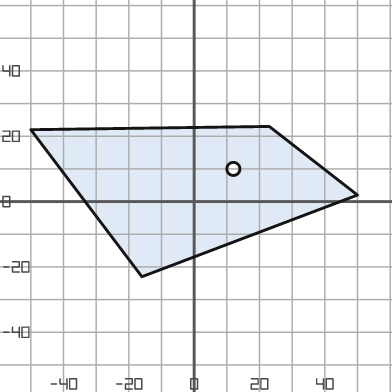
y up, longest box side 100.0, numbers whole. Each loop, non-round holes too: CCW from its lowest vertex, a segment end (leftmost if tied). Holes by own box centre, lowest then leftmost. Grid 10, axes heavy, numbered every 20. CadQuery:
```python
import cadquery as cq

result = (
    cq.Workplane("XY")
    .moveTo(-16.0, -23.0)
    .lineTo(50.0, 2.0)
    .lineTo(23.0, 23.0)
    .lineTo(-50.0, 22.0)
    .close()
    .moveTo(12.0, 10.0)
    .circle(2.0)
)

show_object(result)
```